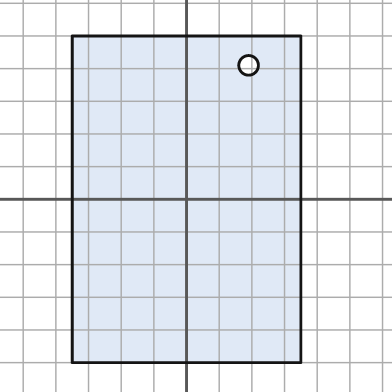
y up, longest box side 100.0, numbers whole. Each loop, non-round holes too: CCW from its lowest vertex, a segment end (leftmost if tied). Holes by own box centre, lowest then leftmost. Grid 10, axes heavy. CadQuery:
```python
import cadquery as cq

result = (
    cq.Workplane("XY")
    .moveTo(-35.0, -50.0)
    .lineTo(35.0, -50.0)
    .lineTo(35.0, 50.0)
    .lineTo(-35.0, 50.0)
    .close()
    .moveTo(19.0, 41.0)
    .circle(3.0)
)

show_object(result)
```